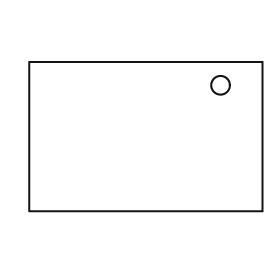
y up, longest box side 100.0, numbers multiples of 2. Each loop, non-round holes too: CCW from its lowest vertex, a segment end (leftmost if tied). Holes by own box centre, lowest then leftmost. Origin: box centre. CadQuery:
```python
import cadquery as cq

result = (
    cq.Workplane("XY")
    .moveTo(-50.0, -32.0)
    .lineTo(50.0, -32.0)
    .lineTo(50.0, 32.0)
    .lineTo(-50.0, 32.0)
    .close()
    .moveTo(32.0, 22.0)
    .circle(4.0)
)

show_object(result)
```